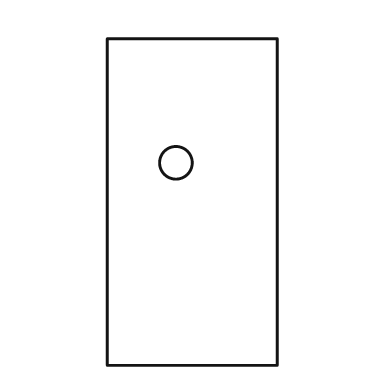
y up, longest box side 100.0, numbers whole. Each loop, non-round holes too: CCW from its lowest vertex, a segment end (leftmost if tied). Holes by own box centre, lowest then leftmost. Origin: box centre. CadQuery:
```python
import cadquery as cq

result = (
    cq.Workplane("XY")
    .moveTo(-26.0, -50.0)
    .lineTo(26.0, -50.0)
    .lineTo(26.0, 50.0)
    .lineTo(-26.0, 50.0)
    .close()
    .moveTo(-5.0, 12.0)
    .circle(5.0)
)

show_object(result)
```